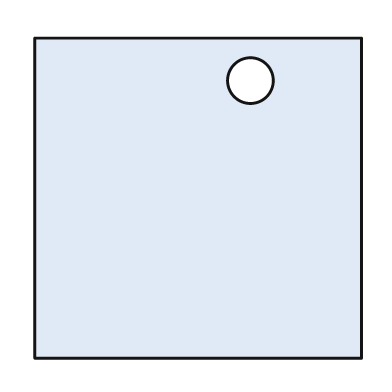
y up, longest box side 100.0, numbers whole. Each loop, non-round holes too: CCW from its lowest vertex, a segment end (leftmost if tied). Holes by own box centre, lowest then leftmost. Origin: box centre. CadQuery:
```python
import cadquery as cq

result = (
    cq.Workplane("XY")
    .moveTo(-50.0, -49.0)
    .lineTo(50.0, -49.0)
    .lineTo(50.0, 49.0)
    .lineTo(-50.0, 49.0)
    .close()
    .moveTo(16.0, 36.0)
    .circle(7.0)
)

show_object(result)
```